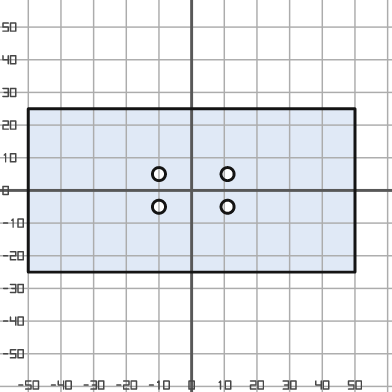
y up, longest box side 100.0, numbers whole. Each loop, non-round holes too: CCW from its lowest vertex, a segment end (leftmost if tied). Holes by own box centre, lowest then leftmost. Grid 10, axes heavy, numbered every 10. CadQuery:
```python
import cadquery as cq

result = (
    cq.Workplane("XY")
    .moveTo(-50.0, -25.0)
    .lineTo(50.0, -25.0)
    .lineTo(50.0, 25.0)
    .lineTo(-50.0, 25.0)
    .close()
    .moveTo(-10.0, -5.0)
    .circle(2.0)
    .moveTo(11.0, -5.0)
    .circle(2.0)
    .moveTo(-10.0, 5.0)
    .circle(2.0)
    .moveTo(11.0, 5.0)
    .circle(2.0)
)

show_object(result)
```